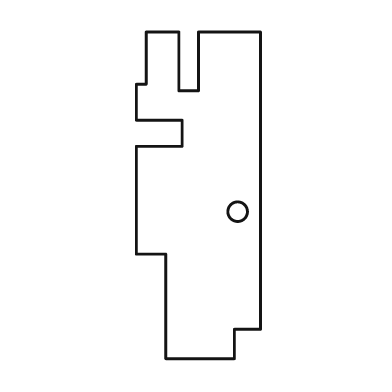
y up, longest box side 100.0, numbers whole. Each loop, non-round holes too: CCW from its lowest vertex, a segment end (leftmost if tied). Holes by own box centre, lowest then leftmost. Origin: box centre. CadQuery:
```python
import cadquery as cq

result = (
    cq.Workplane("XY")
    .moveTo(-10.0, -50.0)
    .lineTo(11.0, -50.0)
    .lineTo(11.0, -41.0)
    .lineTo(19.0, -41.0)
    .lineTo(19.0, 50.0)
    .lineTo(0.0, 50.0)
    .lineTo(0.0, 32.0)
    .lineTo(-6.0, 32.0)
    .lineTo(-6.0, 50.0)
    .lineTo(-16.0, 50.0)
    .lineTo(-16.0, 34.0)
    .lineTo(-19.0, 34.0)
    .lineTo(-19.0, 23.0)
    .lineTo(-5.0, 23.0)
    .lineTo(-5.0, 15.0)
    .lineTo(-19.0, 15.0)
    .lineTo(-19.0, -18.0)
    .lineTo(-10.0, -18.0)
    .close()
    .moveTo(12.0, -5.0)
    .circle(3.0)
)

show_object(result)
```